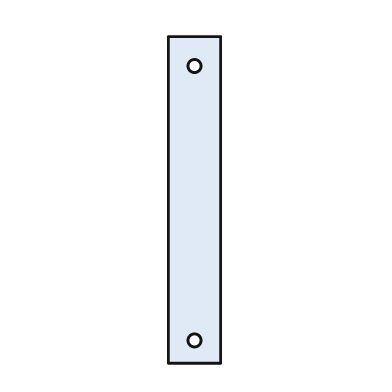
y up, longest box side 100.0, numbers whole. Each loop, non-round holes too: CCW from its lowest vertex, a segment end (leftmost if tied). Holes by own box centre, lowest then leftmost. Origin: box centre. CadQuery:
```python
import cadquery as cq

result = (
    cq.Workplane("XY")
    .moveTo(-8.0, -50.0)
    .lineTo(8.0, -50.0)
    .lineTo(8.0, 50.0)
    .lineTo(-8.0, 50.0)
    .close()
    .moveTo(0.0, -43.0)
    .circle(2.0)
    .moveTo(0.0, 41.0)
    .circle(2.0)
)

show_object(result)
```